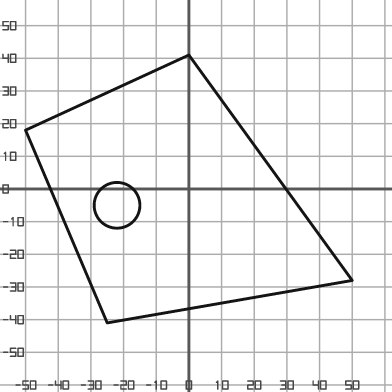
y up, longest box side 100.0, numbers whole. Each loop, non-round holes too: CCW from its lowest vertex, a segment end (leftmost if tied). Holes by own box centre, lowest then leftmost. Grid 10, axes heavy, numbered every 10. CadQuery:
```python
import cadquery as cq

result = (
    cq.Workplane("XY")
    .moveTo(-25.0, -41.0)
    .lineTo(50.0, -28.0)
    .lineTo(0.0, 41.0)
    .lineTo(-50.0, 18.0)
    .close()
    .moveTo(-22.0, -5.0)
    .circle(7.0)
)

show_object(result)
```